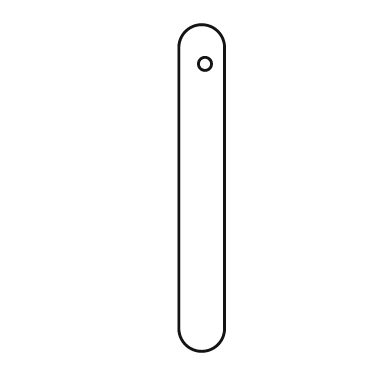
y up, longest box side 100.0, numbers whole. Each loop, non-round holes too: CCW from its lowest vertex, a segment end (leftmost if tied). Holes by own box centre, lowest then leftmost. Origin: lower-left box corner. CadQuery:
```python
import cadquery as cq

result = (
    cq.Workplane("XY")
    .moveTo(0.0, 7.0)
    .threePointArc((7.0, 0.0), (14.0, 7.0))
    .lineTo(14.0, 93.0)
    .threePointArc((7.0, 100.0), (0.0, 93.0))
    .close()
    .moveTo(8.0, 88.0)
    .circle(2.0)
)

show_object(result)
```